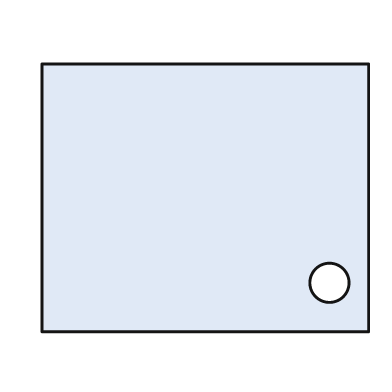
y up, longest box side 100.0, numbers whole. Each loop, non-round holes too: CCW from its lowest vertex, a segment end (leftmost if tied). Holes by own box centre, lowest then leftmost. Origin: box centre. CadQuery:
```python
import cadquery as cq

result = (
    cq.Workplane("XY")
    .moveTo(-50.0, -41.0)
    .lineTo(50.0, -41.0)
    .lineTo(50.0, 41.0)
    .lineTo(-50.0, 41.0)
    .close()
    .moveTo(38.0, -26.0)
    .circle(6.0)
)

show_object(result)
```